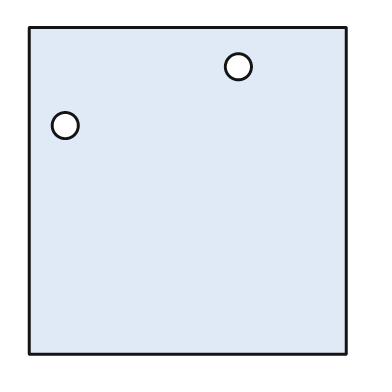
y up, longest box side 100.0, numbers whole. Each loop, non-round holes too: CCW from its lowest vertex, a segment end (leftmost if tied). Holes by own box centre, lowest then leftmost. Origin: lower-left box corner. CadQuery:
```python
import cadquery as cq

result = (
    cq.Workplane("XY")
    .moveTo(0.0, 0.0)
    .lineTo(97.0, 0.0)
    .lineTo(97.0, 100.0)
    .lineTo(0.0, 100.0)
    .close()
    .moveTo(11.0, 70.0)
    .circle(4.0)
    .moveTo(64.0, 88.0)
    .circle(4.0)
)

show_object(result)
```